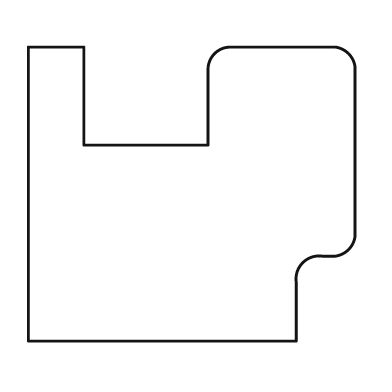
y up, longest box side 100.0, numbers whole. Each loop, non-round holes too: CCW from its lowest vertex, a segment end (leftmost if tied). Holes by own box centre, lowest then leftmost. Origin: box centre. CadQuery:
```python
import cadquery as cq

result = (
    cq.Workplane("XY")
    .moveTo(-50.0, -45.0)
    .lineTo(32.0, -45.0)
    .lineTo(32.0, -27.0)
    .threePointArc((34.0, -21.0), (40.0, -19.0))
    .lineTo(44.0, -19.0)
    .threePointArc((48.0, -17.0), (50.0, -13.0))
    .lineTo(50.0, 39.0)
    .threePointArc((48.0, 43.0), (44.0, 45.0))
    .lineTo(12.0, 45.0)
    .threePointArc((7.0, 43.0), (5.0, 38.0))
    .lineTo(5.0, 15.0)
    .lineTo(-33.0, 15.0)
    .lineTo(-33.0, 45.0)
    .lineTo(-50.0, 45.0)
    .close()
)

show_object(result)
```